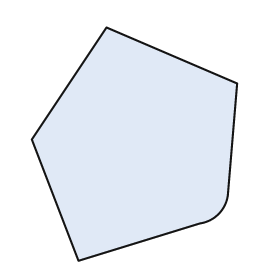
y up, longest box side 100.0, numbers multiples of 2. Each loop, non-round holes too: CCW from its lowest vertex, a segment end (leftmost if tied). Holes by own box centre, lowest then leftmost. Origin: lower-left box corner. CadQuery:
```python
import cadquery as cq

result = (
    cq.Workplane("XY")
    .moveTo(20.0, 0.0)
    .lineTo(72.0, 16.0)
    .threePointArc((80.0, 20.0), (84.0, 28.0))
    .lineTo(88.0, 76.0)
    .lineTo(32.0, 100.0)
    .lineTo(0.0, 52.0)
    .close()
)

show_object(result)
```